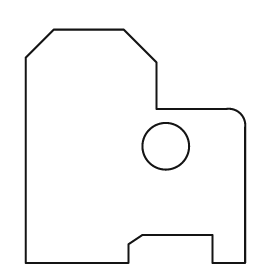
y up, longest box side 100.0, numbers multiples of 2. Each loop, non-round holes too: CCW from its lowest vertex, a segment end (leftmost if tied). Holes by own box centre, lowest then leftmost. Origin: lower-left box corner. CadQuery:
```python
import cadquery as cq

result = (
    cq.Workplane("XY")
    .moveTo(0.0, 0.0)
    .lineTo(44.0, 0.0)
    .lineTo(44.0, 8.0)
    .lineTo(50.0, 12.0)
    .lineTo(80.0, 12.0)
    .lineTo(80.0, 0.0)
    .lineTo(94.0, 0.0)
    .lineTo(94.0, 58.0)
    .threePointArc((92.0, 64.0), (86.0, 66.0))
    .lineTo(56.0, 66.0)
    .lineTo(56.0, 86.0)
    .lineTo(42.0, 100.0)
    .lineTo(12.0, 100.0)
    .lineTo(0.0, 88.0)
    .close()
    .moveTo(60.0, 50.0)
    .circle(10.0)
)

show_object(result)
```